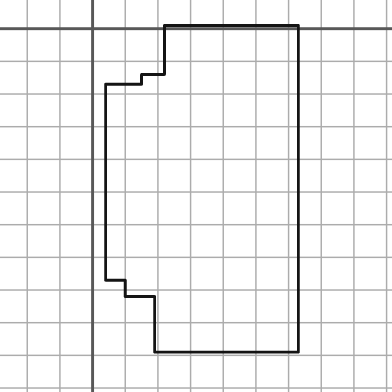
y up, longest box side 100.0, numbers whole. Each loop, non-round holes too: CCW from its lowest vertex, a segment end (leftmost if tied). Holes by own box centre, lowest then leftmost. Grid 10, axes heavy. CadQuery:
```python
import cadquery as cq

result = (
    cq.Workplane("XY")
    .moveTo(19.0, -99.0)
    .lineTo(63.0, -99.0)
    .lineTo(63.0, 1.0)
    .lineTo(22.0, 1.0)
    .lineTo(22.0, -14.0)
    .lineTo(15.0, -14.0)
    .lineTo(15.0, -17.0)
    .lineTo(4.0, -17.0)
    .lineTo(4.0, -77.0)
    .lineTo(10.0, -77.0)
    .lineTo(10.0, -82.0)
    .lineTo(19.0, -82.0)
    .close()
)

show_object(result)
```